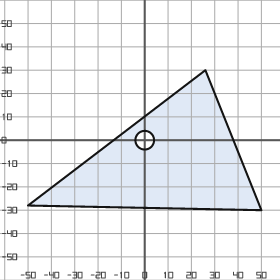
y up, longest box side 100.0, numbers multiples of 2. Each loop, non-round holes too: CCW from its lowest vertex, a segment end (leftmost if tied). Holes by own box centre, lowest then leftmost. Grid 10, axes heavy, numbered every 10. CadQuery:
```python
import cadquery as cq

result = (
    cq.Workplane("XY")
    .moveTo(50.0, -30.0)
    .lineTo(26.0, 30.0)
    .lineTo(-50.0, -28.0)
    .close()
    .moveTo(0.0, 0.0)
    .circle(4.0)
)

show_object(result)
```